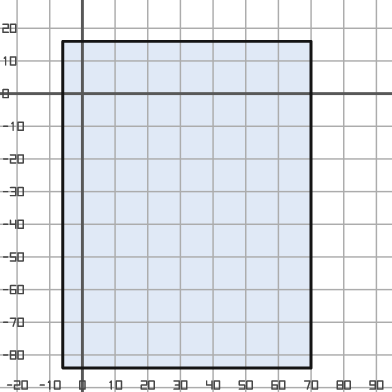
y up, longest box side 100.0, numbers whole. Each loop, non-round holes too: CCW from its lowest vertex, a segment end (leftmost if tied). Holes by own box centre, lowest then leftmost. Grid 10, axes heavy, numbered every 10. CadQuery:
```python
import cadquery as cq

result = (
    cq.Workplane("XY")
    .moveTo(-6.0, -84.0)
    .lineTo(70.0, -84.0)
    .lineTo(70.0, 16.0)
    .lineTo(-6.0, 16.0)
    .close()
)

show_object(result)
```